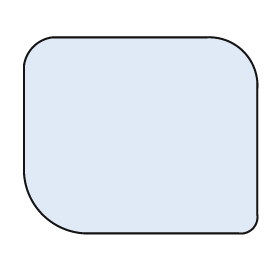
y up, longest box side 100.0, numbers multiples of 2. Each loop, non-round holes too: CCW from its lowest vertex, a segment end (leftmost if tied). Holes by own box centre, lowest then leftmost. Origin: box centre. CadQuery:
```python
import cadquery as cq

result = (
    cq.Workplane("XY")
    .moveTo(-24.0, -42.0)
    .lineTo(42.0, -42.0)
    .threePointArc((48.0, -40.0), (50.0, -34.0))
    .lineTo(50.0, 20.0)
    .threePointArc((44.0, 36.0), (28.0, 42.0))
    .lineTo(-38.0, 42.0)
    .threePointArc((-46.0, 38.0), (-50.0, 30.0))
    .lineTo(-50.0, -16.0)
    .threePointArc((-42.0, -34.0), (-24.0, -42.0))
    .close()
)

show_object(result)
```